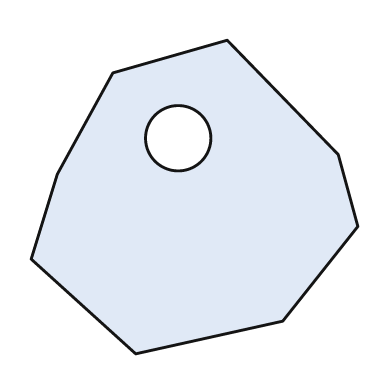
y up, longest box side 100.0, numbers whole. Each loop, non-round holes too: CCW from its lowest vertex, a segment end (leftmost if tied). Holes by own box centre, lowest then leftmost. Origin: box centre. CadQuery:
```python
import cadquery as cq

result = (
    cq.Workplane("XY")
    .moveTo(-18.0, -48.0)
    .lineTo(27.0, -38.0)
    .lineTo(50.0, -9.0)
    .lineTo(44.0, 13.0)
    .lineTo(10.0, 48.0)
    .lineTo(-25.0, 38.0)
    .lineTo(-42.0, 7.0)
    .lineTo(-50.0, -19.0)
    .close()
    .moveTo(-5.0, 18.0)
    .circle(10.0)
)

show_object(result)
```